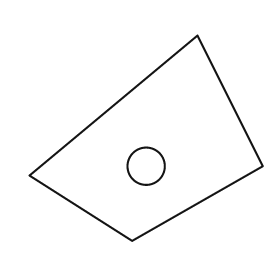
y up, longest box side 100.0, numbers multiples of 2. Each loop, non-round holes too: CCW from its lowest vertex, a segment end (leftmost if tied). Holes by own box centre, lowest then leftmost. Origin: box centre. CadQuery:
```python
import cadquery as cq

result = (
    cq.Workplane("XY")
    .moveTo(-6.0, -44.0)
    .lineTo(50.0, -12.0)
    .lineTo(22.0, 44.0)
    .lineTo(-50.0, -16.0)
    .close()
    .moveTo(0.0, -12.0)
    .circle(8.0)
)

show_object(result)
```